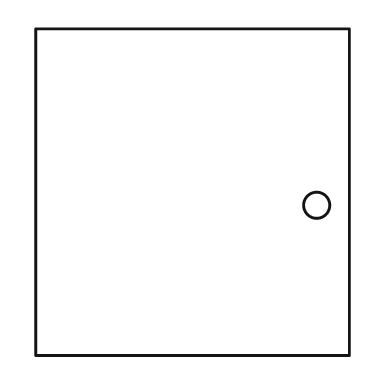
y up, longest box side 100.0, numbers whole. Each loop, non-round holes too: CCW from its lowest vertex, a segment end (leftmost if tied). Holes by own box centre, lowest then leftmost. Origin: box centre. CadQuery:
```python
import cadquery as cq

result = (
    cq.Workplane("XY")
    .moveTo(-48.0, -50.0)
    .lineTo(48.0, -50.0)
    .lineTo(48.0, 50.0)
    .lineTo(-48.0, 50.0)
    .close()
    .moveTo(38.0, -4.0)
    .circle(4.0)
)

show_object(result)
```